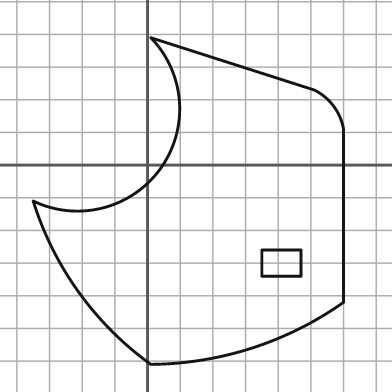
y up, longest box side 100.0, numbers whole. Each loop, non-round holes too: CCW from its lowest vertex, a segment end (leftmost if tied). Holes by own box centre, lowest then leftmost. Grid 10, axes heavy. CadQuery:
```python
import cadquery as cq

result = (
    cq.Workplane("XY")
    .moveTo(1.0, -61.0)
    .threePointArc((32.0, -56.0), (60.0, -42.0))
    .lineTo(60.0, 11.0)
    .threePointArc((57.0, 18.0), (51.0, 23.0))
    .lineTo(1.0, 39.0)
    .threePointArc((4.0, -1.0), (-35.0, -11.0))
    .threePointArc((-21.0, -39.0), (1.0, -61.0))
    .close()
    .moveTo(35.0, -34.0)
    .lineTo(47.0, -34.0)
    .lineTo(47.0, -26.0)
    .lineTo(35.0, -26.0)
    .close()
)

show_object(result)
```